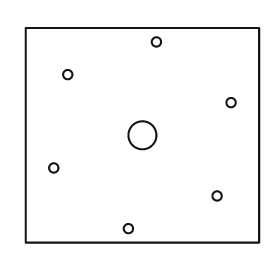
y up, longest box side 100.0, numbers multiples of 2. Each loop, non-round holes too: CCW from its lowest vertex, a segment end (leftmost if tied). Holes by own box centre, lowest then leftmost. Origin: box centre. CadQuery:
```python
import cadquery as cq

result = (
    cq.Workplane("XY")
    .moveTo(-50.0, -46.0)
    .lineTo(50.0, -46.0)
    .lineTo(50.0, 46.0)
    .lineTo(-50.0, 46.0)
    .close()
    .moveTo(-6.0, -40.0)
    .circle(2.0)
    .moveTo(32.0, -26.0)
    .circle(2.0)
    .moveTo(-38.0, -14.0)
    .circle(2.0)
    .moveTo(0.0, 0.0)
    .circle(6.0)
    .moveTo(38.0, 14.0)
    .circle(2.0)
    .moveTo(-32.0, 26.0)
    .circle(2.0)
    .moveTo(6.0, 40.0)
    .circle(2.0)
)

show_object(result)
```